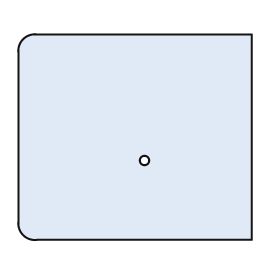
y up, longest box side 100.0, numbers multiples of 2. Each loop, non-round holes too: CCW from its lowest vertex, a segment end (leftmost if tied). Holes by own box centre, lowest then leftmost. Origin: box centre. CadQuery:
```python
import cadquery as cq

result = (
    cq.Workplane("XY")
    .moveTo(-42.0, -44.0)
    .lineTo(50.0, -44.0)
    .lineTo(50.0, 44.0)
    .lineTo(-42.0, 44.0)
    .threePointArc((-48.0, 42.0), (-50.0, 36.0))
    .lineTo(-50.0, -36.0)
    .threePointArc((-48.0, -42.0), (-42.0, -44.0))
    .close()
    .moveTo(4.0, -10.0)
    .circle(2.0)
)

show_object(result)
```